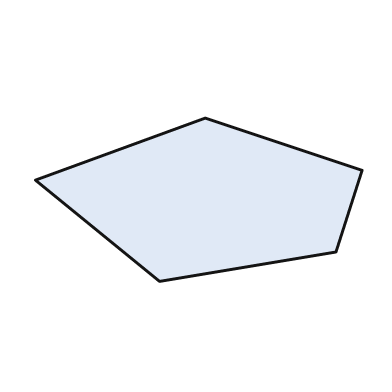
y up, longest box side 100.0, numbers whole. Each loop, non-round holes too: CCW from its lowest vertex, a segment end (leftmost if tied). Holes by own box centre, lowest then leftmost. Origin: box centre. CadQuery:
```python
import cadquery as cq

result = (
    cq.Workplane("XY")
    .moveTo(-12.0, -25.0)
    .lineTo(42.0, -16.0)
    .lineTo(50.0, 9.0)
    .lineTo(2.0, 25.0)
    .lineTo(-50.0, 6.0)
    .close()
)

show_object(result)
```